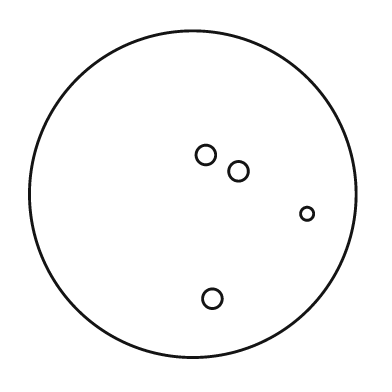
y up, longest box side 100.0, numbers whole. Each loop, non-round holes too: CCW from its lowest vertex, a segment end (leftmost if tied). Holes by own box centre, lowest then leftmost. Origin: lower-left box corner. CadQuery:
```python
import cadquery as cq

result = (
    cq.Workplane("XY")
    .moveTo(50.0, 50.0)
    .circle(50.0)
    .moveTo(56.0, 18.0)
    .circle(3.0)
    .moveTo(85.0, 44.0)
    .circle(2.0)
    .moveTo(64.0, 57.0)
    .circle(3.0)
    .moveTo(54.0, 62.0)
    .circle(3.0)
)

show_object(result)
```